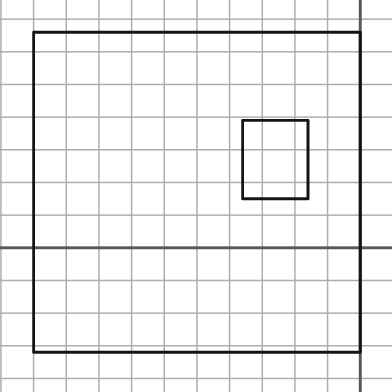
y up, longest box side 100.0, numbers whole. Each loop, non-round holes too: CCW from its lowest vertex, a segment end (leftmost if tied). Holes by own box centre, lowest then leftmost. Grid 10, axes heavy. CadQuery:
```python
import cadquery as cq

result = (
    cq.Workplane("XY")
    .moveTo(-100.0, -32.0)
    .lineTo(0.0, -32.0)
    .lineTo(0.0, 66.0)
    .lineTo(-100.0, 66.0)
    .close()
    .moveTo(-36.0, 15.0)
    .lineTo(-16.0, 15.0)
    .lineTo(-16.0, 39.0)
    .lineTo(-36.0, 39.0)
    .close()
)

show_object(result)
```